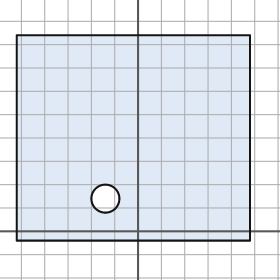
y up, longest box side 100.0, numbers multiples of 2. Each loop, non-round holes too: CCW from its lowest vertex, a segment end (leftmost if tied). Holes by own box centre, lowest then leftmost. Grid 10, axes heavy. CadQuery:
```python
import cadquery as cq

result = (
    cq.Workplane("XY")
    .moveTo(-52.0, -4.0)
    .lineTo(48.0, -4.0)
    .lineTo(48.0, 84.0)
    .lineTo(-52.0, 84.0)
    .close()
    .moveTo(-14.0, 14.0)
    .circle(6.0)
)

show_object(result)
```